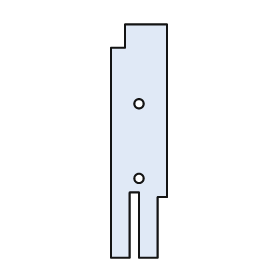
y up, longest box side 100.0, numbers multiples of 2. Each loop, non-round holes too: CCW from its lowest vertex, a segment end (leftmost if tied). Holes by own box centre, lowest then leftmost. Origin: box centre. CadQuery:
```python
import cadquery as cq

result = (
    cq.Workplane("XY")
    .moveTo(-12.0, -50.0)
    .lineTo(-4.0, -50.0)
    .lineTo(-4.0, -22.0)
    .lineTo(0.0, -22.0)
    .lineTo(0.0, -50.0)
    .lineTo(8.0, -50.0)
    .lineTo(8.0, -24.0)
    .lineTo(12.0, -24.0)
    .lineTo(12.0, 50.0)
    .lineTo(-6.0, 50.0)
    .lineTo(-6.0, 40.0)
    .lineTo(-12.0, 40.0)
    .close()
    .moveTo(0.0, -16.0)
    .circle(2.0)
    .moveTo(0.0, 16.0)
    .circle(2.0)
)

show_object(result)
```